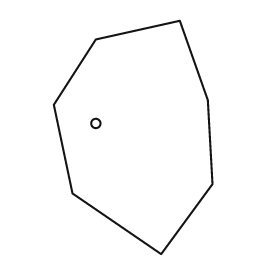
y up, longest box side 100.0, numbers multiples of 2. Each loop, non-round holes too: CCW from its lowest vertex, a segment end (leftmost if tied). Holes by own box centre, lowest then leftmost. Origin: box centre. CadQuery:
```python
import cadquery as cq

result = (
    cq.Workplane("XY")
    .moveTo(12.0, -50.0)
    .lineTo(34.0, -20.0)
    .lineTo(32.0, 16.0)
    .lineTo(20.0, 50.0)
    .lineTo(-16.0, 42.0)
    .lineTo(-34.0, 14.0)
    .lineTo(-26.0, -24.0)
    .close()
    .moveTo(-16.0, 6.0)
    .circle(2.0)
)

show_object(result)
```